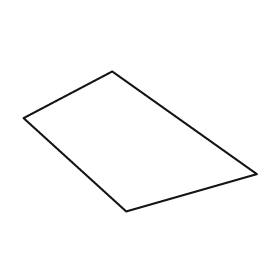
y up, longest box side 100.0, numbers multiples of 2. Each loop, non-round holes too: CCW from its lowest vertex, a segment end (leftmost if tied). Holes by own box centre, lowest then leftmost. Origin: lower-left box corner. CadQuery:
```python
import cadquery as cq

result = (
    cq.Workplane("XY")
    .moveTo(44.0, 0.0)
    .lineTo(100.0, 16.0)
    .lineTo(38.0, 60.0)
    .lineTo(0.0, 40.0)
    .close()
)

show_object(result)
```